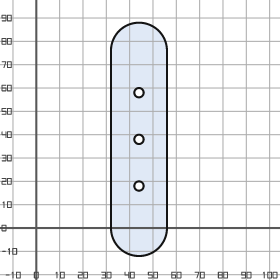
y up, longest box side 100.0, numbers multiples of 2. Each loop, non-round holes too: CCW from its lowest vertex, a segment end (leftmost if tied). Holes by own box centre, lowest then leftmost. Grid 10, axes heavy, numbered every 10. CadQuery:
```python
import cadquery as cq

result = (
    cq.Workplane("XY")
    .moveTo(32.0, 0.0)
    .threePointArc((44.0, -12.0), (56.0, 0.0))
    .lineTo(56.0, 76.0)
    .threePointArc((44.0, 88.0), (32.0, 76.0))
    .close()
    .moveTo(44.0, 18.0)
    .circle(2.0)
    .moveTo(44.0, 38.0)
    .circle(2.0)
    .moveTo(44.0, 58.0)
    .circle(2.0)
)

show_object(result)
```